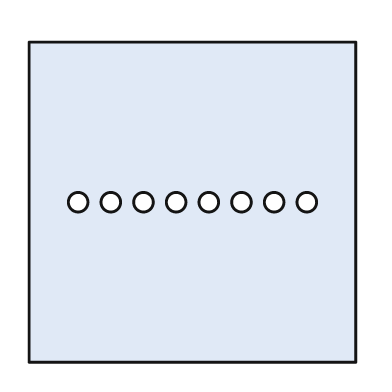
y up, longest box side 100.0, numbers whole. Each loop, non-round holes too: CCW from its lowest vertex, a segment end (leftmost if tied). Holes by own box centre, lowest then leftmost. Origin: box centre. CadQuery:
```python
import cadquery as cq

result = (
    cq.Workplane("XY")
    .moveTo(-50.0, -49.0)
    .lineTo(50.0, -49.0)
    .lineTo(50.0, 49.0)
    .lineTo(-50.0, 49.0)
    .close()
    .moveTo(-35.0, 0.0)
    .circle(3.0)
    .moveTo(-25.0, 0.0)
    .circle(3.0)
    .moveTo(-15.0, 0.0)
    .circle(3.0)
    .moveTo(-5.0, 0.0)
    .circle(3.0)
    .moveTo(5.0, 0.0)
    .circle(3.0)
    .moveTo(15.0, 0.0)
    .circle(3.0)
    .moveTo(25.0, 0.0)
    .circle(3.0)
    .moveTo(35.0, 0.0)
    .circle(3.0)
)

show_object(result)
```